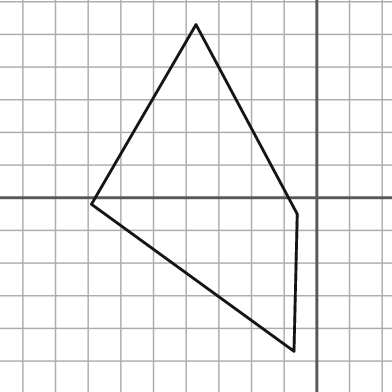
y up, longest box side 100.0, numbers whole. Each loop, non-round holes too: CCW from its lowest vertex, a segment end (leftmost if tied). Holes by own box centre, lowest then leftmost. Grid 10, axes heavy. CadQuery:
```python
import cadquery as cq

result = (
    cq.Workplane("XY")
    .moveTo(-7.0, -47.0)
    .lineTo(-6.0, -5.0)
    .lineTo(-37.0, 53.0)
    .lineTo(-69.0, -2.0)
    .close()
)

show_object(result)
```